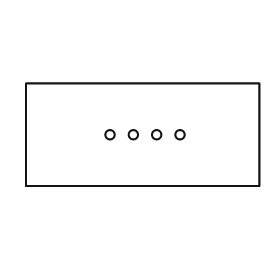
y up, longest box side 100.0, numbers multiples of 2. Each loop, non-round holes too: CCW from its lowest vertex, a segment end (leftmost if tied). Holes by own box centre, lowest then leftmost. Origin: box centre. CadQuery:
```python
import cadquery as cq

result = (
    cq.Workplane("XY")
    .moveTo(-50.0, -22.0)
    .lineTo(50.0, -22.0)
    .lineTo(50.0, 22.0)
    .lineTo(-50.0, 22.0)
    .close()
    .moveTo(-14.0, 0.0)
    .circle(2.0)
    .moveTo(-4.0, 0.0)
    .circle(2.0)
    .moveTo(6.0, 0.0)
    .circle(2.0)
    .moveTo(16.0, 0.0)
    .circle(2.0)
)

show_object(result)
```